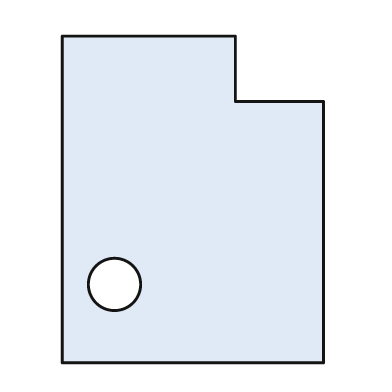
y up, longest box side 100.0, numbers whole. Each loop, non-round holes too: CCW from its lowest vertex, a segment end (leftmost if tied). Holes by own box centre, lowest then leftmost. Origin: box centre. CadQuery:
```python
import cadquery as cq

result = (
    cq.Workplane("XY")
    .moveTo(-40.0, -50.0)
    .lineTo(40.0, -50.0)
    .lineTo(40.0, 30.0)
    .lineTo(13.0, 30.0)
    .lineTo(13.0, 50.0)
    .lineTo(-40.0, 50.0)
    .close()
    .moveTo(-24.0, -26.0)
    .circle(8.0)
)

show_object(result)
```